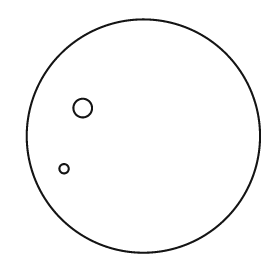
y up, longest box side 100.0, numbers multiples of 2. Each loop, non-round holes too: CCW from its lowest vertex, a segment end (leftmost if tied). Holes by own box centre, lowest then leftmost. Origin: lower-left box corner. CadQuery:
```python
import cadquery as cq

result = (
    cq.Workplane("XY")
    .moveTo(50.0, 50.0)
    .circle(50.0)
    .moveTo(16.0, 36.0)
    .circle(2.0)
    .moveTo(24.0, 62.0)
    .circle(4.0)
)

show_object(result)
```